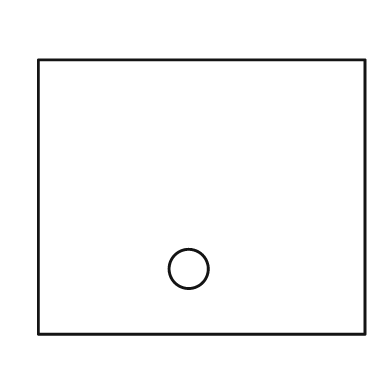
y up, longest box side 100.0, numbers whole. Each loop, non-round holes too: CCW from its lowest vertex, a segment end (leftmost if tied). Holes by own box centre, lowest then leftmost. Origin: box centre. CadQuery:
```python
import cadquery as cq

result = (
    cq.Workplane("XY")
    .moveTo(-50.0, -42.0)
    .lineTo(50.0, -42.0)
    .lineTo(50.0, 42.0)
    .lineTo(-50.0, 42.0)
    .close()
    .moveTo(-4.0, -22.0)
    .circle(6.0)
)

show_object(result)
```